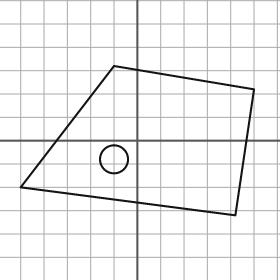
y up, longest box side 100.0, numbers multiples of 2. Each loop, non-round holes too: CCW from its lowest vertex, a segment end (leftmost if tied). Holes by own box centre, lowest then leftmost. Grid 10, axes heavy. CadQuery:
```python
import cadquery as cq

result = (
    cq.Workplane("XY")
    .moveTo(42.0, -32.0)
    .lineTo(50.0, 22.0)
    .lineTo(-10.0, 32.0)
    .lineTo(-50.0, -20.0)
    .close()
    .moveTo(-10.0, -8.0)
    .circle(6.0)
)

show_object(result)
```